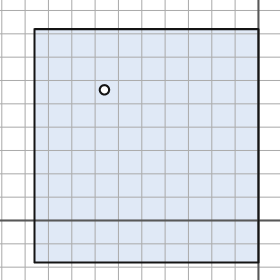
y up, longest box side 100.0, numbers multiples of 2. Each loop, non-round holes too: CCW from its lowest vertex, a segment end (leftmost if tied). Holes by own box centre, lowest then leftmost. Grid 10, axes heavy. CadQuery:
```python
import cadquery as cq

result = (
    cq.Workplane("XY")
    .moveTo(-96.0, -18.0)
    .lineTo(0.0, -18.0)
    .lineTo(0.0, 82.0)
    .lineTo(-96.0, 82.0)
    .close()
    .moveTo(-66.0, 56.0)
    .circle(2.0)
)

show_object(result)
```